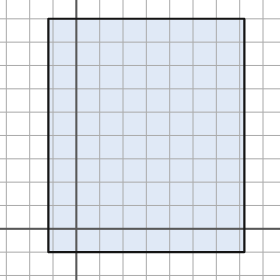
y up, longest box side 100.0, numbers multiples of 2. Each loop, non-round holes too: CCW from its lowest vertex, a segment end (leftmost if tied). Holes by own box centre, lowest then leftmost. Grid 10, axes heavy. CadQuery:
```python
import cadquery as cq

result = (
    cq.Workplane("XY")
    .moveTo(-12.0, -10.0)
    .lineTo(72.0, -10.0)
    .lineTo(72.0, 90.0)
    .lineTo(-12.0, 90.0)
    .close()
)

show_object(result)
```